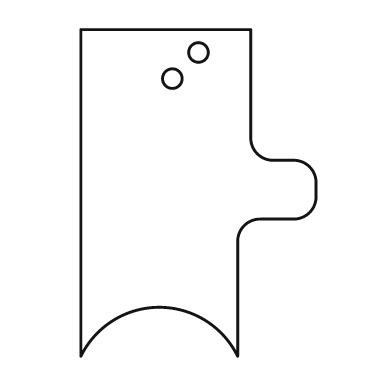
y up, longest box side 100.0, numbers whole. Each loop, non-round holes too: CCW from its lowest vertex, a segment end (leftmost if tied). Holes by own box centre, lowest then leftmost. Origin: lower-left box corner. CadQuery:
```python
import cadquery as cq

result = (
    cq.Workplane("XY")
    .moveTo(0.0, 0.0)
    .threePointArc((24.0, 15.0), (48.0, 0.0))
    .lineTo(48.0, 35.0)
    .threePointArc((50.0, 40.0), (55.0, 42.0))
    .lineTo(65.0, 42.0)
    .threePointArc((70.0, 44.0), (72.0, 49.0))
    .lineTo(72.0, 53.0)
    .threePointArc((70.0, 58.0), (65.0, 60.0))
    .lineTo(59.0, 60.0)
    .threePointArc((54.0, 62.0), (52.0, 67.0))
    .lineTo(52.0, 100.0)
    .lineTo(0.0, 100.0)
    .close()
    .moveTo(28.0, 85.0)
    .circle(3.0)
    .moveTo(36.0, 93.0)
    .circle(3.0)
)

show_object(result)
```